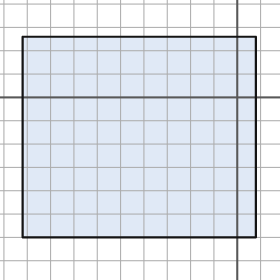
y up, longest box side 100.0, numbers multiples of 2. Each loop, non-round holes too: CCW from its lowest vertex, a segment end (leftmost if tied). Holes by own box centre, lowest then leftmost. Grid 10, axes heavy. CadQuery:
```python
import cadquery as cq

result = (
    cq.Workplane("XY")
    .moveTo(-92.0, -60.0)
    .lineTo(8.0, -60.0)
    .lineTo(8.0, 26.0)
    .lineTo(-92.0, 26.0)
    .close()
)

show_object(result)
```